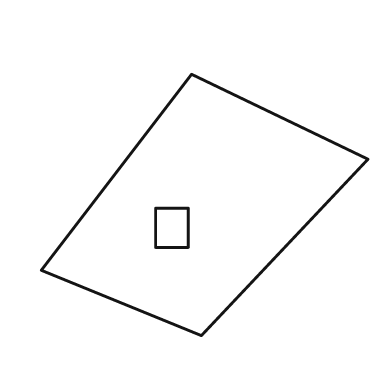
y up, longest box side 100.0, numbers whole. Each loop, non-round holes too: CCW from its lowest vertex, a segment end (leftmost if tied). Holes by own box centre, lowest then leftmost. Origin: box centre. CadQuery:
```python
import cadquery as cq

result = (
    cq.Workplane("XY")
    .moveTo(-1.0, -40.0)
    .lineTo(50.0, 14.0)
    .lineTo(-4.0, 40.0)
    .lineTo(-50.0, -20.0)
    .close()
    .moveTo(-15.0, -13.0)
    .lineTo(-5.0, -13.0)
    .lineTo(-5.0, -1.0)
    .lineTo(-15.0, -1.0)
    .close()
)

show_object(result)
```